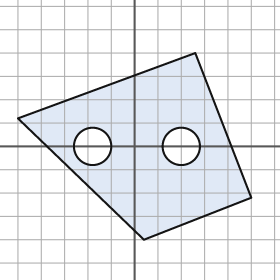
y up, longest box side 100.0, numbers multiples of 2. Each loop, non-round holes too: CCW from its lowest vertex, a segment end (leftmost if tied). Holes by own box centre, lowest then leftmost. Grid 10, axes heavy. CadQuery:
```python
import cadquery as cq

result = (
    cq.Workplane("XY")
    .moveTo(4.0, -40.0)
    .lineTo(50.0, -22.0)
    .lineTo(26.0, 40.0)
    .lineTo(-50.0, 12.0)
    .close()
    .moveTo(-18.0, 0.0)
    .circle(8.0)
    .moveTo(20.0, 0.0)
    .circle(8.0)
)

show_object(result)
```